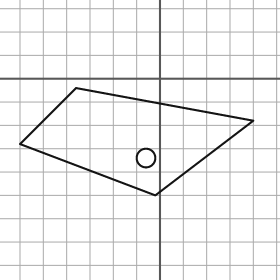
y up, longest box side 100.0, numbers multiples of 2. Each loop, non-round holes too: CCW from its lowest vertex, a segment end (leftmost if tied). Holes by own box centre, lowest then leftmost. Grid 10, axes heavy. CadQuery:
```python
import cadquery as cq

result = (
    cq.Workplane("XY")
    .moveTo(-2.0, -50.0)
    .lineTo(40.0, -18.0)
    .lineTo(-36.0, -4.0)
    .lineTo(-60.0, -28.0)
    .close()
    .moveTo(-6.0, -34.0)
    .circle(4.0)
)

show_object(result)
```